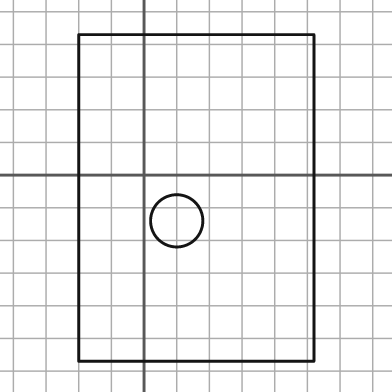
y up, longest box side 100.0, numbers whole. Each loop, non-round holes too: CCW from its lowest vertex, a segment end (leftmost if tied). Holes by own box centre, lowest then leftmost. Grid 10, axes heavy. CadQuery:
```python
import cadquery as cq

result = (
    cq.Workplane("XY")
    .moveTo(-20.0, -57.0)
    .lineTo(52.0, -57.0)
    .lineTo(52.0, 43.0)
    .lineTo(-20.0, 43.0)
    .close()
    .moveTo(10.0, -14.0)
    .circle(8.0)
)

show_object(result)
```